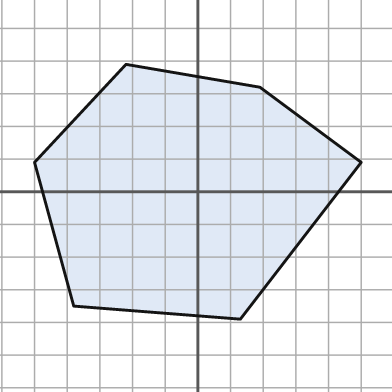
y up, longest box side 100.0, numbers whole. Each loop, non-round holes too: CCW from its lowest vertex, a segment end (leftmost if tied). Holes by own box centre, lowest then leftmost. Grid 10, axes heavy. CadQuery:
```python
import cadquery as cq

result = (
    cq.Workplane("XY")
    .moveTo(13.0, -39.0)
    .lineTo(50.0, 9.0)
    .lineTo(19.0, 32.0)
    .lineTo(-22.0, 39.0)
    .lineTo(-50.0, 9.0)
    .lineTo(-38.0, -35.0)
    .close()
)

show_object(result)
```